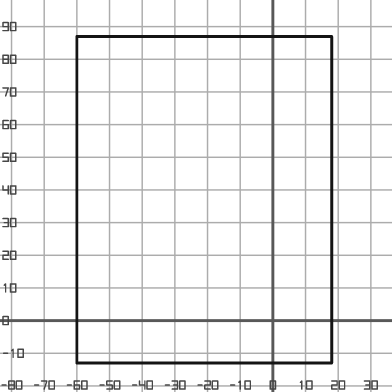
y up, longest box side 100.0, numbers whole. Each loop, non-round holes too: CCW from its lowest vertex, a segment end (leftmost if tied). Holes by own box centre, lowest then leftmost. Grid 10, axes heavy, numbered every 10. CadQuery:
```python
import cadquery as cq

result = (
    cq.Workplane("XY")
    .moveTo(-60.0, -13.0)
    .lineTo(18.0, -13.0)
    .lineTo(18.0, 87.0)
    .lineTo(-60.0, 87.0)
    .close()
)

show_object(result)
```